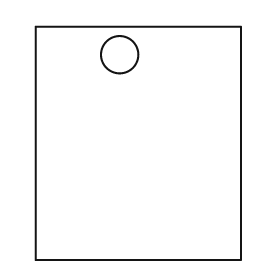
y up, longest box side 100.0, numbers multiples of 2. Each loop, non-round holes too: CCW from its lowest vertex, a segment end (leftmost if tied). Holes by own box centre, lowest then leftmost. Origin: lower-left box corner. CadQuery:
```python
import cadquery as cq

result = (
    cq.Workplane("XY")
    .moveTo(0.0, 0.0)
    .lineTo(88.0, 0.0)
    .lineTo(88.0, 100.0)
    .lineTo(0.0, 100.0)
    .close()
    .moveTo(36.0, 88.0)
    .circle(8.0)
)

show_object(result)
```